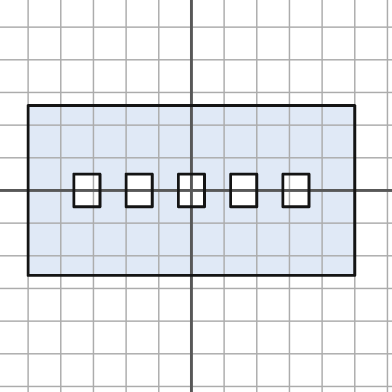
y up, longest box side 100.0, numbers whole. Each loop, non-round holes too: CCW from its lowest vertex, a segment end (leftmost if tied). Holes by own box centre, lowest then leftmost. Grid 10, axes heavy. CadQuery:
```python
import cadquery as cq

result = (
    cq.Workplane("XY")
    .moveTo(-50.0, -26.0)
    .lineTo(50.0, -26.0)
    .lineTo(50.0, 26.0)
    .lineTo(-50.0, 26.0)
    .close()
    .moveTo(-36.0, -5.0)
    .lineTo(-28.0, -5.0)
    .lineTo(-28.0, 5.0)
    .lineTo(-36.0, 5.0)
    .close()
    .moveTo(-20.0, -5.0)
    .lineTo(-12.0, -5.0)
    .lineTo(-12.0, 5.0)
    .lineTo(-20.0, 5.0)
    .close()
    .moveTo(-4.0, -5.0)
    .lineTo(4.0, -5.0)
    .lineTo(4.0, 5.0)
    .lineTo(-4.0, 5.0)
    .close()
    .moveTo(12.0, -5.0)
    .lineTo(20.0, -5.0)
    .lineTo(20.0, 5.0)
    .lineTo(12.0, 5.0)
    .close()
    .moveTo(28.0, -5.0)
    .lineTo(36.0, -5.0)
    .lineTo(36.0, 5.0)
    .lineTo(28.0, 5.0)
    .close()
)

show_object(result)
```